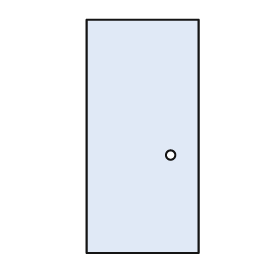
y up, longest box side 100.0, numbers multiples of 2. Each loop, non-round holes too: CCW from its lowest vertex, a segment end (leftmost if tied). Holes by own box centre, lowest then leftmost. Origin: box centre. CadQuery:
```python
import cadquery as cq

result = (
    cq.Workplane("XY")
    .moveTo(-24.0, -50.0)
    .lineTo(24.0, -50.0)
    .lineTo(24.0, 50.0)
    .lineTo(-24.0, 50.0)
    .close()
    .moveTo(12.0, -8.0)
    .circle(2.0)
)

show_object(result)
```